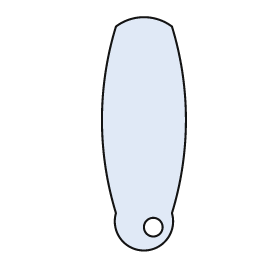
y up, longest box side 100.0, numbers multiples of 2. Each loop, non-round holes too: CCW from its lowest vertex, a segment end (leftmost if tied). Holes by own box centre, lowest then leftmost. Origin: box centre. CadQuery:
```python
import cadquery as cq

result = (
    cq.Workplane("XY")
    .moveTo(-12.0, -34.0)
    .threePointArc((0.0, -50.0), (12.0, -34.0))
    .threePointArc((18.0, 6.0), (12.0, 46.0))
    .threePointArc((0.0, 50.0), (-12.0, 46.0))
    .threePointArc((-18.0, 6.0), (-12.0, -34.0))
    .close()
    .moveTo(4.0, -40.0)
    .circle(4.0)
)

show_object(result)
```